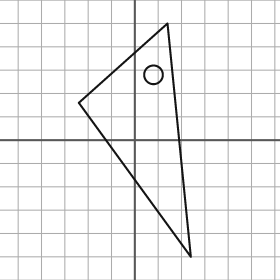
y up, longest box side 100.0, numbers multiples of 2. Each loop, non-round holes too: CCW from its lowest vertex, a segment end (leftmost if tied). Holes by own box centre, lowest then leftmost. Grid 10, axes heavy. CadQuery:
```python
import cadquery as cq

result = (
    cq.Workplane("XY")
    .moveTo(24.0, -50.0)
    .lineTo(14.0, 50.0)
    .lineTo(-24.0, 16.0)
    .close()
    .moveTo(8.0, 28.0)
    .circle(4.0)
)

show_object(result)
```